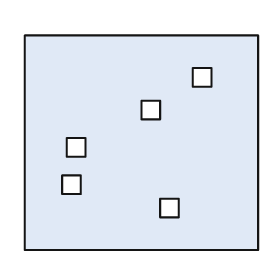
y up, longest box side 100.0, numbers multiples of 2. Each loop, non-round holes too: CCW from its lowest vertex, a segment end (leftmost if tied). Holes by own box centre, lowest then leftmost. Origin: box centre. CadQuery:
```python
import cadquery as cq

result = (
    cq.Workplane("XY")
    .moveTo(-50.0, -46.0)
    .lineTo(50.0, -46.0)
    .lineTo(50.0, 46.0)
    .lineTo(-50.0, 46.0)
    .close()
    .moveTo(8.0, -32.0)
    .lineTo(16.0, -32.0)
    .lineTo(16.0, -24.0)
    .lineTo(8.0, -24.0)
    .close()
    .moveTo(-34.0, -22.0)
    .lineTo(-26.0, -22.0)
    .lineTo(-26.0, -14.0)
    .lineTo(-34.0, -14.0)
    .close()
    .moveTo(-32.0, -6.0)
    .lineTo(-24.0, -6.0)
    .lineTo(-24.0, 2.0)
    .lineTo(-32.0, 2.0)
    .close()
    .moveTo(0.0, 10.0)
    .lineTo(8.0, 10.0)
    .lineTo(8.0, 18.0)
    .lineTo(0.0, 18.0)
    .close()
    .moveTo(22.0, 24.0)
    .lineTo(30.0, 24.0)
    .lineTo(30.0, 32.0)
    .lineTo(22.0, 32.0)
    .close()
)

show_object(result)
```